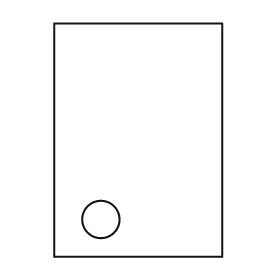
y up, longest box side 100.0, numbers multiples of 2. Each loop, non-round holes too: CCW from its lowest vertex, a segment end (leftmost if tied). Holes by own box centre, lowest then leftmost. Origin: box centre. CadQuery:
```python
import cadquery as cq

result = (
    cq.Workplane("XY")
    .moveTo(-36.0, -50.0)
    .lineTo(36.0, -50.0)
    .lineTo(36.0, 50.0)
    .lineTo(-36.0, 50.0)
    .close()
    .moveTo(-16.0, -34.0)
    .circle(8.0)
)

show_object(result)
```